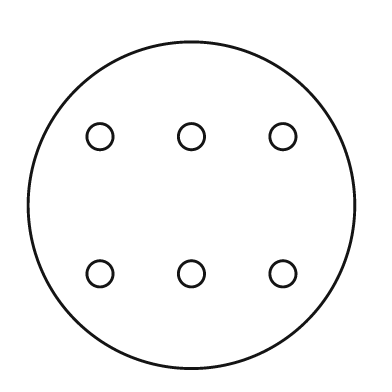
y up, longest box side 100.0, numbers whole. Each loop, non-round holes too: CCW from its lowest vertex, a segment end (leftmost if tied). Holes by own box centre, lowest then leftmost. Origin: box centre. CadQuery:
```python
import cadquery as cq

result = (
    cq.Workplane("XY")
    .moveTo(0.0, 0.0)
    .circle(50.0)
    .moveTo(-28.0, -21.0)
    .circle(4.0)
    .moveTo(0.0, -21.0)
    .circle(4.0)
    .moveTo(28.0, -21.0)
    .circle(4.0)
    .moveTo(-28.0, 21.0)
    .circle(4.0)
    .moveTo(0.0, 21.0)
    .circle(4.0)
    .moveTo(28.0, 21.0)
    .circle(4.0)
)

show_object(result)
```